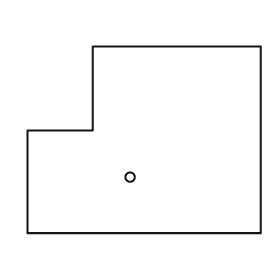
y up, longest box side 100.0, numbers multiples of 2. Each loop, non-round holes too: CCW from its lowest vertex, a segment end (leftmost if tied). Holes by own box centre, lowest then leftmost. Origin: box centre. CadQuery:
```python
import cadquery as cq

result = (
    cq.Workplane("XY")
    .moveTo(-50.0, -40.0)
    .lineTo(50.0, -40.0)
    .lineTo(50.0, 40.0)
    .lineTo(-22.0, 40.0)
    .lineTo(-22.0, 4.0)
    .lineTo(-50.0, 4.0)
    .close()
    .moveTo(-6.0, -16.0)
    .circle(2.0)
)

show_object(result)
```